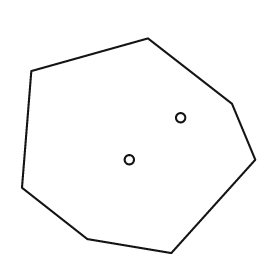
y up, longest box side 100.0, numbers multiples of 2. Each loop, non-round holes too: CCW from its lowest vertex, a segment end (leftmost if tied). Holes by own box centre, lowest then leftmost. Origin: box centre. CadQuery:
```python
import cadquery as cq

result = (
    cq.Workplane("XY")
    .moveTo(14.0, -46.0)
    .lineTo(50.0, -6.0)
    .lineTo(40.0, 18.0)
    .lineTo(4.0, 46.0)
    .lineTo(-46.0, 32.0)
    .lineTo(-50.0, -18.0)
    .lineTo(-22.0, -40.0)
    .close()
    .moveTo(-4.0, -6.0)
    .circle(2.0)
    .moveTo(18.0, 12.0)
    .circle(2.0)
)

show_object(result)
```